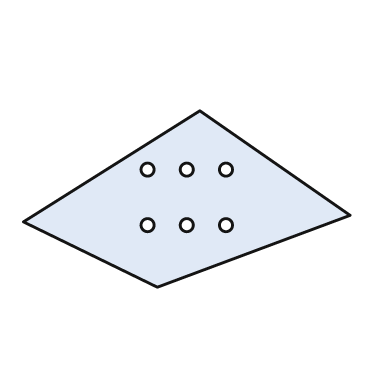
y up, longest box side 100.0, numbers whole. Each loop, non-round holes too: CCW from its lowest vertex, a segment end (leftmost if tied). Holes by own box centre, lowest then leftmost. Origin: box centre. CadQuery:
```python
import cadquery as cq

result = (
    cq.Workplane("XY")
    .moveTo(-9.0, -27.0)
    .lineTo(50.0, -5.0)
    .lineTo(4.0, 27.0)
    .lineTo(-50.0, -7.0)
    .close()
    .moveTo(-12.0, -8.0)
    .circle(2.0)
    .moveTo(0.0, -8.0)
    .circle(2.0)
    .moveTo(12.0, -8.0)
    .circle(2.0)
    .moveTo(-12.0, 9.0)
    .circle(2.0)
    .moveTo(0.0, 9.0)
    .circle(2.0)
    .moveTo(12.0, 9.0)
    .circle(2.0)
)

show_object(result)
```